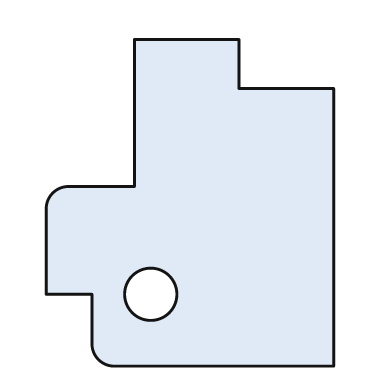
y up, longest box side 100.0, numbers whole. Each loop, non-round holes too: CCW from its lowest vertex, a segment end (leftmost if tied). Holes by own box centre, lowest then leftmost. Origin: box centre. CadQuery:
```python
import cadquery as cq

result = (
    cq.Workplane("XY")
    .moveTo(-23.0, -50.0)
    .lineTo(44.0, -50.0)
    .lineTo(44.0, 35.0)
    .lineTo(15.0, 35.0)
    .lineTo(15.0, 50.0)
    .lineTo(-17.0, 50.0)
    .lineTo(-17.0, 5.0)
    .lineTo(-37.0, 5.0)
    .threePointArc((-42.0, 3.0), (-44.0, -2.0))
    .lineTo(-44.0, -28.0)
    .lineTo(-30.0, -28.0)
    .lineTo(-30.0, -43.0)
    .threePointArc((-28.0, -48.0), (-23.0, -50.0))
    .close()
    .moveTo(-12.0, -28.0)
    .circle(8.0)
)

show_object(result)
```